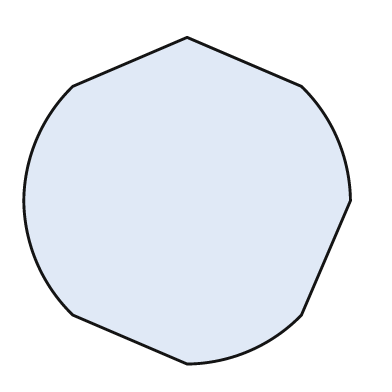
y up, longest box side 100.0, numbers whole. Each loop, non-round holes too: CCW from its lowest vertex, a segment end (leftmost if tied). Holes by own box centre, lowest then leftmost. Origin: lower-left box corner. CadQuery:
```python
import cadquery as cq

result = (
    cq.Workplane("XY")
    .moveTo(50.0, 0.0)
    .threePointArc((69.0, 4.0), (85.0, 15.0))
    .lineTo(100.0, 50.0)
    .threePointArc((96.0, 69.0), (85.0, 85.0))
    .lineTo(50.0, 100.0)
    .lineTo(15.0, 85.0)
    .threePointArc((4.0, 69.0), (0.0, 50.0))
    .threePointArc((4.0, 31.0), (15.0, 15.0))
    .close()
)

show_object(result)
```